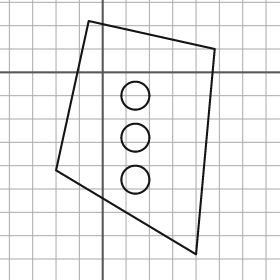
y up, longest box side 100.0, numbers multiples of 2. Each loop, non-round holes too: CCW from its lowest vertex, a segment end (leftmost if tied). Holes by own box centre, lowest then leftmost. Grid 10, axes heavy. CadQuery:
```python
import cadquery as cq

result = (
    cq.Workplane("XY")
    .moveTo(40.0, -78.0)
    .lineTo(48.0, 10.0)
    .lineTo(-6.0, 22.0)
    .lineTo(-20.0, -42.0)
    .close()
    .moveTo(14.0, -46.0)
    .circle(6.0)
    .moveTo(14.0, -28.0)
    .circle(6.0)
    .moveTo(14.0, -10.0)
    .circle(6.0)
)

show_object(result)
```